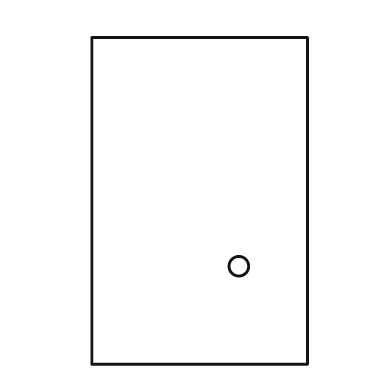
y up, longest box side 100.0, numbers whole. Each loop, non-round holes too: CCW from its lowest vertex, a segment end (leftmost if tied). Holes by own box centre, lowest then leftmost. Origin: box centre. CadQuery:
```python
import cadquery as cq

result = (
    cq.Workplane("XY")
    .moveTo(-33.0, -50.0)
    .lineTo(33.0, -50.0)
    .lineTo(33.0, 50.0)
    .lineTo(-33.0, 50.0)
    .close()
    .moveTo(12.0, -20.0)
    .circle(3.0)
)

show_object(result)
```